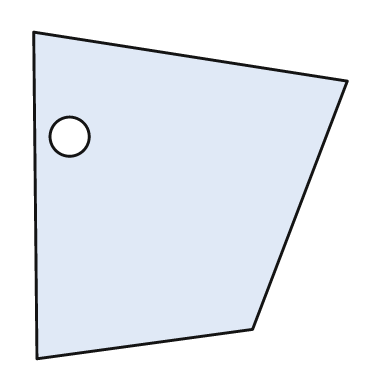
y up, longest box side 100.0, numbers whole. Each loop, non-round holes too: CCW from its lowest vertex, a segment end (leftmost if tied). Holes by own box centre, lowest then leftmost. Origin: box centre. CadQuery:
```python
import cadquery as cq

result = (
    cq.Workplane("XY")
    .moveTo(-47.0, -50.0)
    .lineTo(19.0, -41.0)
    .lineTo(48.0, 35.0)
    .lineTo(-48.0, 50.0)
    .close()
    .moveTo(-37.0, 18.0)
    .circle(6.0)
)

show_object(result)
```